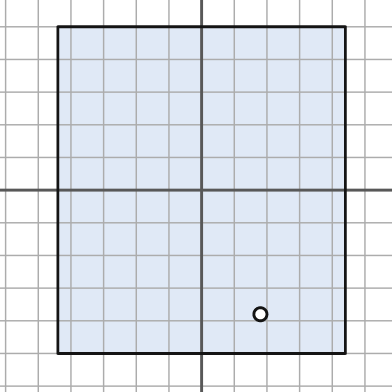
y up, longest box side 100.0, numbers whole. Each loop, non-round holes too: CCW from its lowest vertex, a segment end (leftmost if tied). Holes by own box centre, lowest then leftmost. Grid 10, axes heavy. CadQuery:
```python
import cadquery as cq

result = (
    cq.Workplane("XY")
    .moveTo(-44.0, -50.0)
    .lineTo(44.0, -50.0)
    .lineTo(44.0, 50.0)
    .lineTo(-44.0, 50.0)
    .close()
    .moveTo(18.0, -38.0)
    .circle(2.0)
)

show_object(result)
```